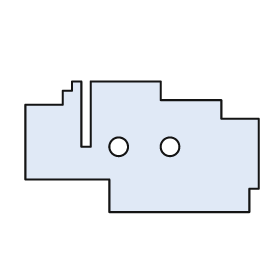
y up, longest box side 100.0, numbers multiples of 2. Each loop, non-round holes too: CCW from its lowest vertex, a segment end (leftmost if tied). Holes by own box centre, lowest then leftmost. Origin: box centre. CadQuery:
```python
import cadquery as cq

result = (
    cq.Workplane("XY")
    .moveTo(-14.0, -28.0)
    .lineTo(46.0, -28.0)
    .lineTo(46.0, -18.0)
    .lineTo(50.0, -18.0)
    .lineTo(50.0, 12.0)
    .lineTo(34.0, 12.0)
    .lineTo(34.0, 20.0)
    .lineTo(8.0, 20.0)
    .lineTo(8.0, 28.0)
    .lineTo(-22.0, 28.0)
    .lineTo(-22.0, 0.0)
    .lineTo(-26.0, 0.0)
    .lineTo(-26.0, 28.0)
    .lineTo(-30.0, 28.0)
    .lineTo(-30.0, 24.0)
    .lineTo(-34.0, 24.0)
    .lineTo(-34.0, 18.0)
    .lineTo(-50.0, 18.0)
    .lineTo(-50.0, -14.0)
    .lineTo(-14.0, -14.0)
    .close()
    .moveTo(-10.0, 0.0)
    .circle(4.0)
    .moveTo(12.0, 0.0)
    .circle(4.0)
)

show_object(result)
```